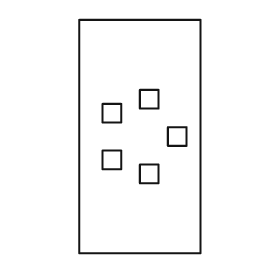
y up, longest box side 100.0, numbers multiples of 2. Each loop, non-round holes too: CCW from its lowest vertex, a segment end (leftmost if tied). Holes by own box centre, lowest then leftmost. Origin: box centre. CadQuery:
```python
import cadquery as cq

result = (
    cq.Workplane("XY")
    .moveTo(-26.0, -50.0)
    .lineTo(26.0, -50.0)
    .lineTo(26.0, 50.0)
    .lineTo(-26.0, 50.0)
    .close()
    .moveTo(0.0, -20.0)
    .lineTo(8.0, -20.0)
    .lineTo(8.0, -12.0)
    .lineTo(0.0, -12.0)
    .close()
    .moveTo(-16.0, -14.0)
    .lineTo(-8.0, -14.0)
    .lineTo(-8.0, -6.0)
    .lineTo(-16.0, -6.0)
    .close()
    .moveTo(12.0, -4.0)
    .lineTo(20.0, -4.0)
    .lineTo(20.0, 4.0)
    .lineTo(12.0, 4.0)
    .close()
    .moveTo(-16.0, 6.0)
    .lineTo(-8.0, 6.0)
    .lineTo(-8.0, 14.0)
    .lineTo(-16.0, 14.0)
    .close()
    .moveTo(0.0, 12.0)
    .lineTo(8.0, 12.0)
    .lineTo(8.0, 20.0)
    .lineTo(0.0, 20.0)
    .close()
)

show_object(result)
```